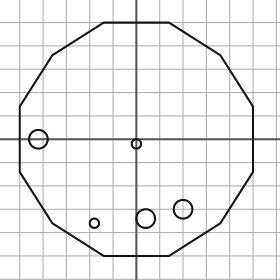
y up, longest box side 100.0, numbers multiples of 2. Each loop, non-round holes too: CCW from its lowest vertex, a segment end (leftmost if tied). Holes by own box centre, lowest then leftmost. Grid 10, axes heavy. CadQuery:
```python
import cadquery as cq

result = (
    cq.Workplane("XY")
    .moveTo(-14.0, -50.0)
    .lineTo(14.0, -50.0)
    .lineTo(36.0, -36.0)
    .lineTo(50.0, -14.0)
    .lineTo(50.0, 14.0)
    .lineTo(36.0, 36.0)
    .lineTo(14.0, 50.0)
    .lineTo(-14.0, 50.0)
    .lineTo(-36.0, 36.0)
    .lineTo(-50.0, 14.0)
    .lineTo(-50.0, -14.0)
    .lineTo(-36.0, -36.0)
    .close()
    .moveTo(-18.0, -36.0)
    .circle(2.0)
    .moveTo(4.0, -34.0)
    .circle(4.0)
    .moveTo(20.0, -30.0)
    .circle(4.0)
    .moveTo(0.0, -2.0)
    .circle(2.0)
    .moveTo(-42.0, 0.0)
    .circle(4.0)
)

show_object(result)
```